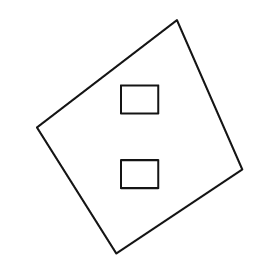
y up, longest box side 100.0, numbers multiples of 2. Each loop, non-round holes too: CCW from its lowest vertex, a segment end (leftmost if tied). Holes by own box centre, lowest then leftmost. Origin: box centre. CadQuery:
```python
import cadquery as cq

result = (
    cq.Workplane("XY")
    .moveTo(-10.0, -50.0)
    .lineTo(44.0, -14.0)
    .lineTo(16.0, 50.0)
    .lineTo(-44.0, 4.0)
    .close()
    .moveTo(-8.0, -22.0)
    .lineTo(8.0, -22.0)
    .lineTo(8.0, -10.0)
    .lineTo(-8.0, -10.0)
    .close()
    .moveTo(-8.0, 10.0)
    .lineTo(8.0, 10.0)
    .lineTo(8.0, 22.0)
    .lineTo(-8.0, 22.0)
    .close()
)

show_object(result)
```